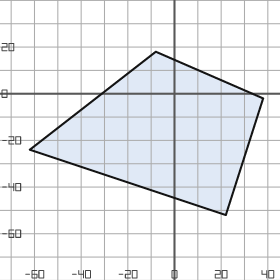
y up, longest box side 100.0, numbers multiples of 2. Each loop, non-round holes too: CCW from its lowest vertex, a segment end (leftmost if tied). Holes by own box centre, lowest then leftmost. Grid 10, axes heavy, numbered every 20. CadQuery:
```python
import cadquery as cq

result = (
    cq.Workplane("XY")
    .moveTo(22.0, -52.0)
    .lineTo(38.0, -2.0)
    .lineTo(-8.0, 18.0)
    .lineTo(-62.0, -24.0)
    .close()
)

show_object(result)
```